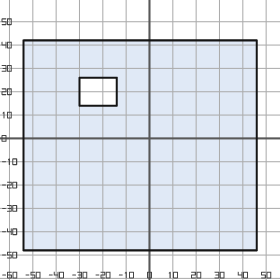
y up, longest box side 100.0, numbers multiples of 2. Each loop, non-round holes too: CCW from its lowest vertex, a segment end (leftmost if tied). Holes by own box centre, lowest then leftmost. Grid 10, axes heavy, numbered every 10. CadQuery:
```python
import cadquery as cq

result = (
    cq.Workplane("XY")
    .moveTo(-54.0, -48.0)
    .lineTo(46.0, -48.0)
    .lineTo(46.0, 42.0)
    .lineTo(-54.0, 42.0)
    .close()
    .moveTo(-30.0, 14.0)
    .lineTo(-14.0, 14.0)
    .lineTo(-14.0, 26.0)
    .lineTo(-30.0, 26.0)
    .close()
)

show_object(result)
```